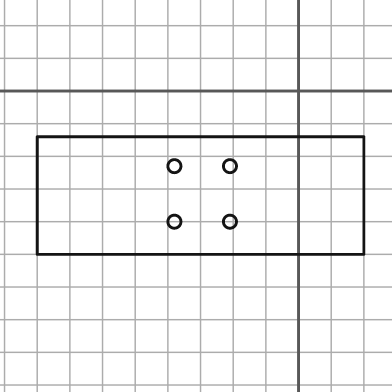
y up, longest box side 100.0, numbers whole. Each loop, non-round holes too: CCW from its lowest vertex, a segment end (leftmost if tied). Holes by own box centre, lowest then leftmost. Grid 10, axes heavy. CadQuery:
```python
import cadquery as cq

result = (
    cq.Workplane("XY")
    .moveTo(-80.0, -50.0)
    .lineTo(20.0, -50.0)
    .lineTo(20.0, -14.0)
    .lineTo(-80.0, -14.0)
    .close()
    .moveTo(-38.0, -40.0)
    .circle(2.0)
    .moveTo(-21.0, -40.0)
    .circle(2.0)
    .moveTo(-38.0, -23.0)
    .circle(2.0)
    .moveTo(-21.0, -23.0)
    .circle(2.0)
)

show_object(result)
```